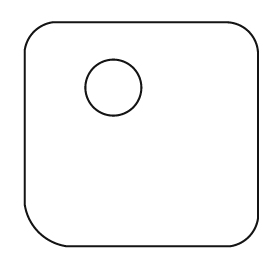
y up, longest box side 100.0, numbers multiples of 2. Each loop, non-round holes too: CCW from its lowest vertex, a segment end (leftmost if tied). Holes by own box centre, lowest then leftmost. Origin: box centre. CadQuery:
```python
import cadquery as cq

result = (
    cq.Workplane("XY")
    .moveTo(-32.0, -48.0)
    .lineTo(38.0, -48.0)
    .threePointArc((46.0, -44.0), (50.0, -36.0))
    .lineTo(50.0, 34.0)
    .threePointArc((46.0, 44.0), (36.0, 48.0))
    .lineTo(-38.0, 48.0)
    .threePointArc((-46.0, 44.0), (-50.0, 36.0))
    .lineTo(-50.0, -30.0)
    .threePointArc((-44.0, -42.0), (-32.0, -48.0))
    .close()
    .moveTo(-12.0, 20.0)
    .circle(12.0)
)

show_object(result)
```